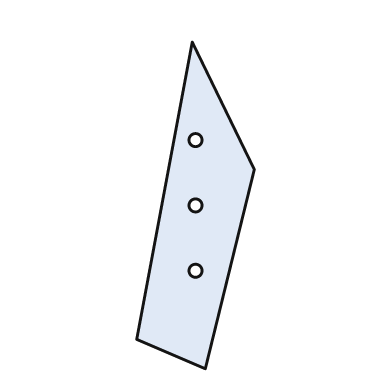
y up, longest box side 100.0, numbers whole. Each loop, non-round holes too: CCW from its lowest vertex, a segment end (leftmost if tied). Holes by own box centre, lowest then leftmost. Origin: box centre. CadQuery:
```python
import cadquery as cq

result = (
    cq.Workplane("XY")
    .moveTo(3.0, -50.0)
    .lineTo(18.0, 11.0)
    .lineTo(-1.0, 50.0)
    .lineTo(-18.0, -41.0)
    .close()
    .moveTo(0.0, -20.0)
    .circle(2.0)
    .moveTo(0.0, 0.0)
    .circle(2.0)
    .moveTo(0.0, 20.0)
    .circle(2.0)
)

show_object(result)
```